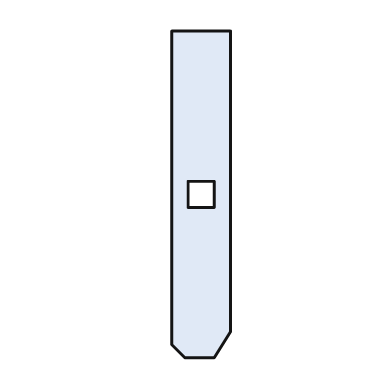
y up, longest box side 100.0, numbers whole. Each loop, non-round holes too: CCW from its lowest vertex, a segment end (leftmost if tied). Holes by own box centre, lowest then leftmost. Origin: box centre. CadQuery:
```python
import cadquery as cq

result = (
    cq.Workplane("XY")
    .moveTo(-5.0, -50.0)
    .lineTo(4.0, -50.0)
    .lineTo(9.0, -42.0)
    .lineTo(9.0, 50.0)
    .lineTo(-9.0, 50.0)
    .lineTo(-9.0, -46.0)
    .close()
    .moveTo(-4.0, -4.0)
    .lineTo(4.0, -4.0)
    .lineTo(4.0, 4.0)
    .lineTo(-4.0, 4.0)
    .close()
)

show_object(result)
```